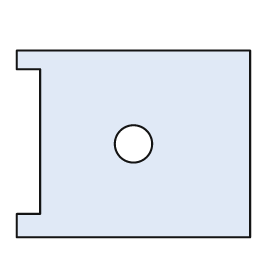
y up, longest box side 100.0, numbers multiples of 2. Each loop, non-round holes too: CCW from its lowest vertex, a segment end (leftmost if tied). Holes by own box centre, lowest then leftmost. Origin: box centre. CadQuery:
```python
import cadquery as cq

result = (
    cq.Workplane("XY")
    .moveTo(-50.0, -40.0)
    .lineTo(50.0, -40.0)
    .lineTo(50.0, 40.0)
    .lineTo(-50.0, 40.0)
    .lineTo(-50.0, 32.0)
    .lineTo(-40.0, 32.0)
    .lineTo(-40.0, -30.0)
    .lineTo(-50.0, -30.0)
    .close()
    .moveTo(0.0, 0.0)
    .circle(8.0)
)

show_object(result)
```